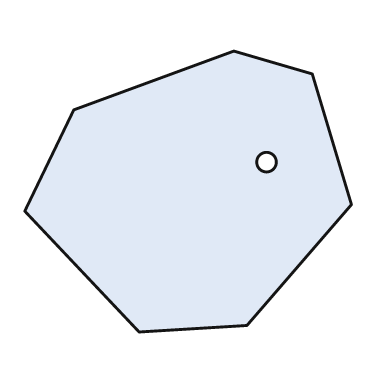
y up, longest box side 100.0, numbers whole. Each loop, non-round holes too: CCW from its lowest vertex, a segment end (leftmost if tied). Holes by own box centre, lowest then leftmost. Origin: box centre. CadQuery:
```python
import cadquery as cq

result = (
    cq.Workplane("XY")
    .moveTo(-15.0, -43.0)
    .lineTo(18.0, -41.0)
    .lineTo(50.0, -4.0)
    .lineTo(38.0, 36.0)
    .lineTo(14.0, 43.0)
    .lineTo(-35.0, 25.0)
    .lineTo(-50.0, -6.0)
    .close()
    .moveTo(24.0, 9.0)
    .circle(3.0)
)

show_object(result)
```